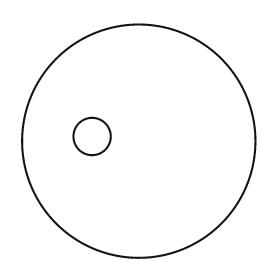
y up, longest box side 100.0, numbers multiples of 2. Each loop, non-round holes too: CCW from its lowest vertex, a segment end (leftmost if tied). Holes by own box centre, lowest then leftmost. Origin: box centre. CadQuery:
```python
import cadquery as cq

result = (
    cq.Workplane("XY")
    .moveTo(0.0, 0.0)
    .circle(50.0)
    .moveTo(-20.0, 2.0)
    .circle(8.0)
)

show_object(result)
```